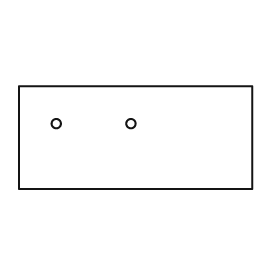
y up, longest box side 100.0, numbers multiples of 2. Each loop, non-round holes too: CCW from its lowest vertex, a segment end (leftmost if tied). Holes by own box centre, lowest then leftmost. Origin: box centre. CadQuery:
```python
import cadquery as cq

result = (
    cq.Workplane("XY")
    .moveTo(-50.0, -22.0)
    .lineTo(50.0, -22.0)
    .lineTo(50.0, 22.0)
    .lineTo(-50.0, 22.0)
    .close()
    .moveTo(-34.0, 6.0)
    .circle(2.0)
    .moveTo(-2.0, 6.0)
    .circle(2.0)
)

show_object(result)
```